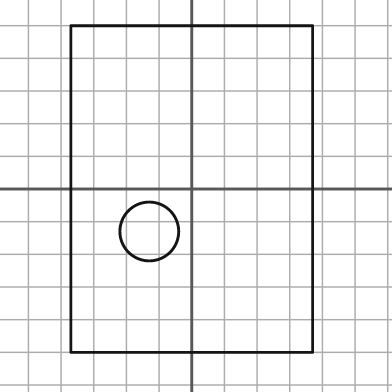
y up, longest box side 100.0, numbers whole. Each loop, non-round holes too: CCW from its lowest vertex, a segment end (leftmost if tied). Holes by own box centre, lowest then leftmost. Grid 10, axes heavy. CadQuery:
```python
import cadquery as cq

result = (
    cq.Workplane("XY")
    .moveTo(-37.0, -50.0)
    .lineTo(37.0, -50.0)
    .lineTo(37.0, 50.0)
    .lineTo(-37.0, 50.0)
    .close()
    .moveTo(-13.0, -13.0)
    .circle(9.0)
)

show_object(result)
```